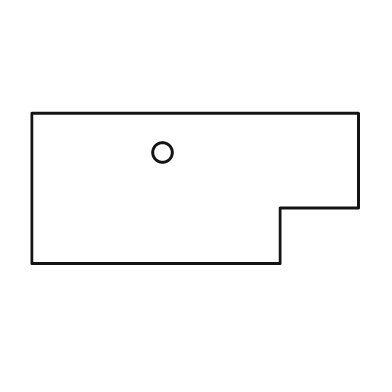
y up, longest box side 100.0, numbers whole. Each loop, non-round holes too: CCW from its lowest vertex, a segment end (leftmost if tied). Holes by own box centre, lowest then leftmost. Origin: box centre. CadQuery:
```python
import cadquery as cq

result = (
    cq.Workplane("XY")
    .moveTo(-50.0, -23.0)
    .lineTo(26.0, -23.0)
    .lineTo(26.0, -6.0)
    .lineTo(50.0, -6.0)
    .lineTo(50.0, 23.0)
    .lineTo(-50.0, 23.0)
    .close()
    .moveTo(-10.0, 11.0)
    .circle(3.0)
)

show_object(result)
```